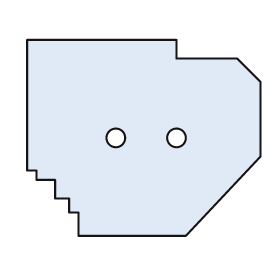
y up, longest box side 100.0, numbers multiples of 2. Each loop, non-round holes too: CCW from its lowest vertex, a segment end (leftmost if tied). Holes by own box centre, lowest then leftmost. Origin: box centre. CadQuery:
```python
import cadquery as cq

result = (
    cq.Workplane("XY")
    .moveTo(-28.0, -42.0)
    .lineTo(18.0, -42.0)
    .lineTo(50.0, -8.0)
    .lineTo(50.0, 24.0)
    .lineTo(40.0, 34.0)
    .lineTo(14.0, 34.0)
    .lineTo(14.0, 42.0)
    .lineTo(-50.0, 42.0)
    .lineTo(-50.0, -14.0)
    .lineTo(-46.0, -14.0)
    .lineTo(-46.0, -18.0)
    .lineTo(-38.0, -18.0)
    .lineTo(-38.0, -26.0)
    .lineTo(-32.0, -26.0)
    .lineTo(-32.0, -32.0)
    .lineTo(-28.0, -32.0)
    .close()
    .moveTo(-12.0, 0.0)
    .circle(4.0)
    .moveTo(14.0, 0.0)
    .circle(4.0)
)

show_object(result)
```